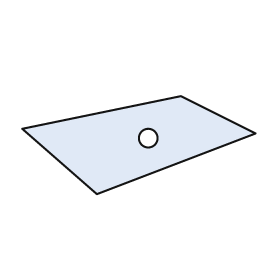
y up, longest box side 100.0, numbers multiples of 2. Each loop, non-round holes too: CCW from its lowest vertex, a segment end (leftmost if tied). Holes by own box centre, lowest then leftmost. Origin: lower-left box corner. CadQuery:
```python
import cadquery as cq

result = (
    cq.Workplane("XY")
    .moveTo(32.0, 0.0)
    .lineTo(100.0, 26.0)
    .lineTo(68.0, 42.0)
    .lineTo(0.0, 28.0)
    .close()
    .moveTo(54.0, 24.0)
    .circle(4.0)
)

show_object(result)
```